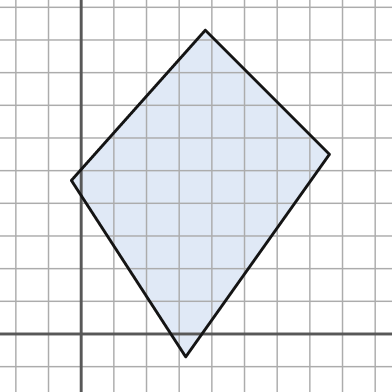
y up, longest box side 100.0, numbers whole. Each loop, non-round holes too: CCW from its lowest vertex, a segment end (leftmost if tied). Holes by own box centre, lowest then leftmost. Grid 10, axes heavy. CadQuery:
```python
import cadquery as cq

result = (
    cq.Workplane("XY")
    .moveTo(32.0, -7.0)
    .lineTo(76.0, 55.0)
    .lineTo(38.0, 93.0)
    .lineTo(-3.0, 47.0)
    .close()
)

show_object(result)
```